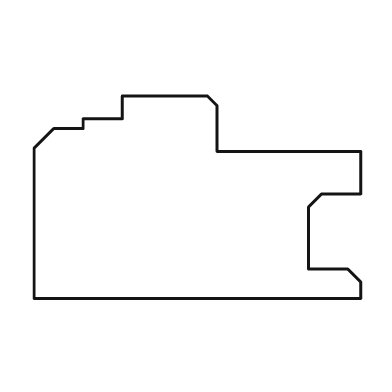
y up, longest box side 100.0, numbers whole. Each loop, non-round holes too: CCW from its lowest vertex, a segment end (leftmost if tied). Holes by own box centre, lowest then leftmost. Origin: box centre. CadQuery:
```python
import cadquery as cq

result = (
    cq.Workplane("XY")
    .moveTo(-50.0, -31.0)
    .lineTo(50.0, -31.0)
    .lineTo(50.0, -26.0)
    .lineTo(46.0, -22.0)
    .lineTo(34.0, -22.0)
    .lineTo(34.0, -3.0)
    .lineTo(38.0, 1.0)
    .lineTo(50.0, 1.0)
    .lineTo(50.0, 14.0)
    .lineTo(6.0, 14.0)
    .lineTo(6.0, 28.0)
    .lineTo(3.0, 31.0)
    .lineTo(-23.0, 31.0)
    .lineTo(-23.0, 24.0)
    .lineTo(-35.0, 24.0)
    .lineTo(-35.0, 21.0)
    .lineTo(-44.0, 21.0)
    .lineTo(-50.0, 15.0)
    .close()
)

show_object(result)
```